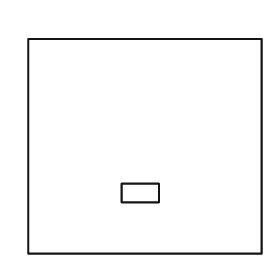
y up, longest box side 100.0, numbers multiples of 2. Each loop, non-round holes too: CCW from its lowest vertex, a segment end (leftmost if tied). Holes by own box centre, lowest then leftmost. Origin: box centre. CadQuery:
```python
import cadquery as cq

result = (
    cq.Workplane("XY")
    .moveTo(-50.0, -46.0)
    .lineTo(50.0, -46.0)
    .lineTo(50.0, 46.0)
    .lineTo(-50.0, 46.0)
    .close()
    .moveTo(-10.0, -24.0)
    .lineTo(6.0, -24.0)
    .lineTo(6.0, -16.0)
    .lineTo(-10.0, -16.0)
    .close()
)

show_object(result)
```